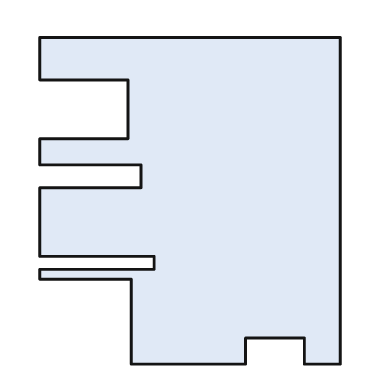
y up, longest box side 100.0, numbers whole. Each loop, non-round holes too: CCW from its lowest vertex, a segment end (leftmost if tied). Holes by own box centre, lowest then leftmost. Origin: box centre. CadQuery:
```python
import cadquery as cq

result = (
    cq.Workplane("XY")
    .moveTo(-18.0, -50.0)
    .lineTo(17.0, -50.0)
    .lineTo(17.0, -42.0)
    .lineTo(35.0, -42.0)
    .lineTo(35.0, -50.0)
    .lineTo(46.0, -50.0)
    .lineTo(46.0, 50.0)
    .lineTo(-46.0, 50.0)
    .lineTo(-46.0, 37.0)
    .lineTo(-19.0, 37.0)
    .lineTo(-19.0, 19.0)
    .lineTo(-46.0, 19.0)
    .lineTo(-46.0, 11.0)
    .lineTo(-15.0, 11.0)
    .lineTo(-15.0, 4.0)
    .lineTo(-46.0, 4.0)
    .lineTo(-46.0, -17.0)
    .lineTo(-11.0, -17.0)
    .lineTo(-11.0, -21.0)
    .lineTo(-46.0, -21.0)
    .lineTo(-46.0, -24.0)
    .lineTo(-18.0, -24.0)
    .close()
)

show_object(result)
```